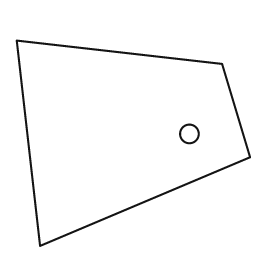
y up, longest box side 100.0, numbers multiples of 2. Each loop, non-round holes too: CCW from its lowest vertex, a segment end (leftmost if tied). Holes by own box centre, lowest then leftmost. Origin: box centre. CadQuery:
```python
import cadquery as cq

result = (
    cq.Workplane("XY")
    .moveTo(-40.0, -44.0)
    .lineTo(50.0, -6.0)
    .lineTo(38.0, 34.0)
    .lineTo(-50.0, 44.0)
    .close()
    .moveTo(24.0, 4.0)
    .circle(4.0)
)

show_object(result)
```